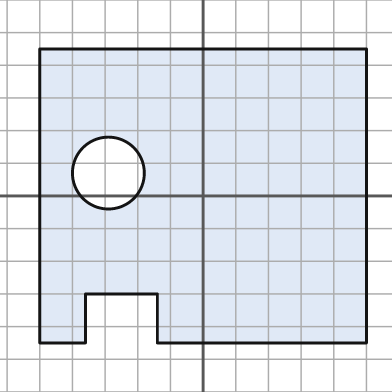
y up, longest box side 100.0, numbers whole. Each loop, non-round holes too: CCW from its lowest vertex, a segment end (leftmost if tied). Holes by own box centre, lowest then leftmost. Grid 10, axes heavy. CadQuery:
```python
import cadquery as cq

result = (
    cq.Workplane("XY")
    .moveTo(-50.0, -45.0)
    .lineTo(-36.0, -45.0)
    .lineTo(-36.0, -30.0)
    .lineTo(-14.0, -30.0)
    .lineTo(-14.0, -45.0)
    .lineTo(50.0, -45.0)
    .lineTo(50.0, 45.0)
    .lineTo(-50.0, 45.0)
    .close()
    .moveTo(-29.0, 7.0)
    .circle(11.0)
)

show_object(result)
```